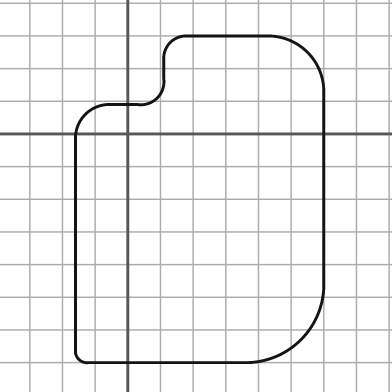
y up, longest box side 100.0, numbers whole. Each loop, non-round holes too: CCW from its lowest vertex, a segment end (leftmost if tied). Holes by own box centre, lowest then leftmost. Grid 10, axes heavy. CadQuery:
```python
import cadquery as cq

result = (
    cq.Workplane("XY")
    .moveTo(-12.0, -70.0)
    .lineTo(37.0, -70.0)
    .threePointArc((53.0, -63.0), (60.0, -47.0))
    .lineTo(60.0, 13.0)
    .threePointArc((55.0, 25.0), (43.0, 30.0))
    .lineTo(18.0, 30.0)
    .threePointArc((13.0, 28.0), (11.0, 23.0))
    .lineTo(11.0, 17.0)
    .threePointArc((9.0, 11.0), (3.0, 9.0))
    .lineTo(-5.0, 9.0)
    .threePointArc((-13.0, 6.0), (-16.0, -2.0))
    .lineTo(-16.0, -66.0)
    .threePointArc((-15.0, -69.0), (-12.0, -70.0))
    .close()
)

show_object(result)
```